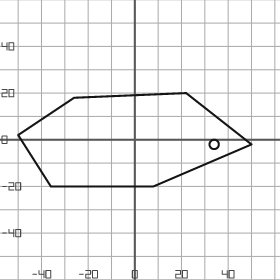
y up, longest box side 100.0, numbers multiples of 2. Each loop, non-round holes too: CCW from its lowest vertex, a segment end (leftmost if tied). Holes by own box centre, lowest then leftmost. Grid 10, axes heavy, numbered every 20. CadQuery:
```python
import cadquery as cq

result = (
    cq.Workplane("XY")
    .moveTo(-36.0, -20.0)
    .lineTo(8.0, -20.0)
    .lineTo(50.0, -2.0)
    .lineTo(22.0, 20.0)
    .lineTo(-26.0, 18.0)
    .lineTo(-50.0, 2.0)
    .close()
    .moveTo(34.0, -2.0)
    .circle(2.0)
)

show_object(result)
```